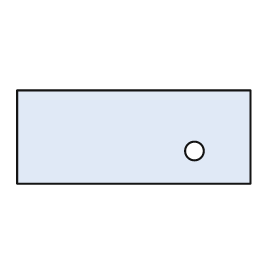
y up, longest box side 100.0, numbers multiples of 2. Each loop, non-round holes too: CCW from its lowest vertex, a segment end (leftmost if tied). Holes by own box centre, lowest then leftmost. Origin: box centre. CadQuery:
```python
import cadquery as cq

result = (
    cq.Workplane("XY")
    .moveTo(-50.0, -20.0)
    .lineTo(50.0, -20.0)
    .lineTo(50.0, 20.0)
    .lineTo(-50.0, 20.0)
    .close()
    .moveTo(26.0, -6.0)
    .circle(4.0)
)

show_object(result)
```